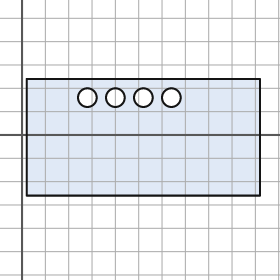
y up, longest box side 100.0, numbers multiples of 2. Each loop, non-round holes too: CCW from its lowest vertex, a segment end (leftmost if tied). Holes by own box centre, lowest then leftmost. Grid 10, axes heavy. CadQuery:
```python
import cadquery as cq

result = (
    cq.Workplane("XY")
    .moveTo(2.0, -26.0)
    .lineTo(102.0, -26.0)
    .lineTo(102.0, 24.0)
    .lineTo(2.0, 24.0)
    .close()
    .moveTo(28.0, 16.0)
    .circle(4.0)
    .moveTo(40.0, 16.0)
    .circle(4.0)
    .moveTo(52.0, 16.0)
    .circle(4.0)
    .moveTo(64.0, 16.0)
    .circle(4.0)
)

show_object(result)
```